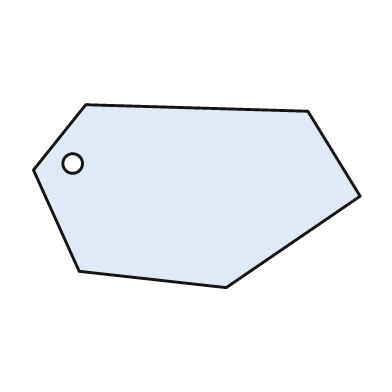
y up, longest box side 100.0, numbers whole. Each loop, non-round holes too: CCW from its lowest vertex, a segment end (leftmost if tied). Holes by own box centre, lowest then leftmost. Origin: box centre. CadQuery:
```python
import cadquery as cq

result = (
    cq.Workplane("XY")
    .moveTo(9.0, -28.0)
    .lineTo(50.0, 0.0)
    .lineTo(34.0, 26.0)
    .lineTo(-34.0, 28.0)
    .lineTo(-50.0, 8.0)
    .lineTo(-36.0, -23.0)
    .close()
    .moveTo(-38.0, 10.0)
    .circle(3.0)
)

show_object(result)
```